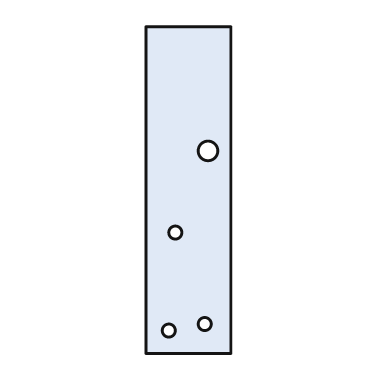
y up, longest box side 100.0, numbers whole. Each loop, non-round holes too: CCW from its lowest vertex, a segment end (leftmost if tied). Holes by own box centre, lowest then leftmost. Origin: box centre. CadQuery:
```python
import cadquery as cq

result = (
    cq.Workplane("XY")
    .moveTo(-13.0, -50.0)
    .lineTo(13.0, -50.0)
    .lineTo(13.0, 50.0)
    .lineTo(-13.0, 50.0)
    .close()
    .moveTo(-6.0, -43.0)
    .circle(2.0)
    .moveTo(5.0, -41.0)
    .circle(2.0)
    .moveTo(-4.0, -13.0)
    .circle(2.0)
    .moveTo(6.0, 12.0)
    .circle(3.0)
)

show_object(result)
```